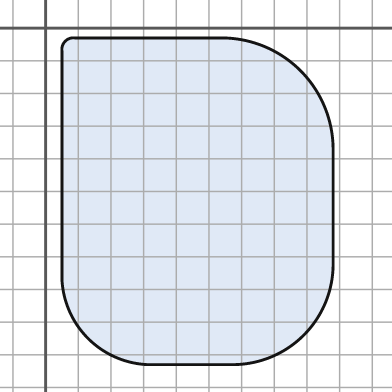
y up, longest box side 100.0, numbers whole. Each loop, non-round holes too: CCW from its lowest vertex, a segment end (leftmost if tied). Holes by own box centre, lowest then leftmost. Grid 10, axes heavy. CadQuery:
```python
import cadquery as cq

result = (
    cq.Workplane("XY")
    .moveTo(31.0, -103.0)
    .lineTo(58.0, -103.0)
    .threePointArc((79.0, -94.0), (88.0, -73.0))
    .lineTo(88.0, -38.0)
    .threePointArc((78.0, -13.0), (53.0, -3.0))
    .lineTo(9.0, -3.0)
    .threePointArc((6.0, -4.0), (5.0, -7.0))
    .lineTo(5.0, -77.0)
    .threePointArc((13.0, -95.0), (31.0, -103.0))
    .close()
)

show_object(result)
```